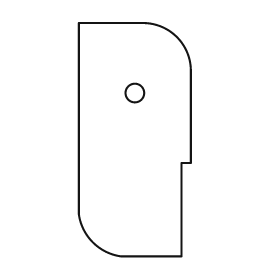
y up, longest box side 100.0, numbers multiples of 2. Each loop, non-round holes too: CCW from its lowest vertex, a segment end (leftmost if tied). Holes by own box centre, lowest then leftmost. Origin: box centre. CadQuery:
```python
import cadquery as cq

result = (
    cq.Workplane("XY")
    .moveTo(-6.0, -50.0)
    .lineTo(20.0, -50.0)
    .lineTo(20.0, -10.0)
    .lineTo(24.0, -10.0)
    .lineTo(24.0, 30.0)
    .threePointArc((18.0, 44.0), (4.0, 50.0))
    .lineTo(-24.0, 50.0)
    .lineTo(-24.0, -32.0)
    .threePointArc((-18.0, -44.0), (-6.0, -50.0))
    .close()
    .moveTo(0.0, 20.0)
    .circle(4.0)
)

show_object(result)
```